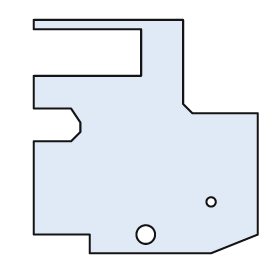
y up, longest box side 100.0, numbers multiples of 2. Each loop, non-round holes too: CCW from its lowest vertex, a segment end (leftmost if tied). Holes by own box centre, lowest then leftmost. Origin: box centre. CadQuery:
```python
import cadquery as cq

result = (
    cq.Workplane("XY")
    .moveTo(-24.0, -50.0)
    .lineTo(28.0, -50.0)
    .lineTo(48.0, -42.0)
    .lineTo(48.0, 10.0)
    .lineTo(20.0, 10.0)
    .lineTo(16.0, 14.0)
    .lineTo(16.0, 50.0)
    .lineTo(-48.0, 50.0)
    .lineTo(-48.0, 46.0)
    .lineTo(-2.0, 46.0)
    .lineTo(-2.0, 26.0)
    .lineTo(-48.0, 26.0)
    .lineTo(-48.0, 12.0)
    .lineTo(-32.0, 12.0)
    .lineTo(-28.0, 6.0)
    .lineTo(-28.0, 2.0)
    .lineTo(-32.0, -2.0)
    .lineTo(-48.0, -2.0)
    .lineTo(-48.0, -42.0)
    .lineTo(-24.0, -42.0)
    .close()
    .moveTo(0.0, -42.0)
    .circle(4.0)
    .moveTo(28.0, -28.0)
    .circle(2.0)
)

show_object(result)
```